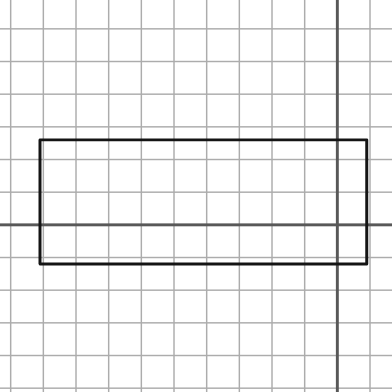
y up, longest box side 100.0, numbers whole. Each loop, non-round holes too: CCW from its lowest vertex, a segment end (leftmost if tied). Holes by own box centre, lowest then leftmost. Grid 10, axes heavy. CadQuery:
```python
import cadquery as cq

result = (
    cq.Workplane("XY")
    .moveTo(-91.0, -12.0)
    .lineTo(9.0, -12.0)
    .lineTo(9.0, 26.0)
    .lineTo(-91.0, 26.0)
    .close()
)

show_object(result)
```